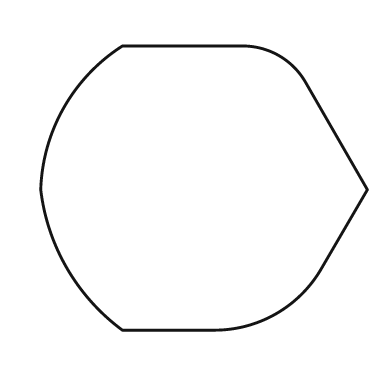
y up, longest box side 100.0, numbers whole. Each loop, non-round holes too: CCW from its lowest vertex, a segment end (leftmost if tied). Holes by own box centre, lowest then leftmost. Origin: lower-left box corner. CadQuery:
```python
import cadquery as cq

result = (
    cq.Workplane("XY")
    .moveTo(25.0, 0.0)
    .lineTo(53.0, 0.0)
    .threePointArc((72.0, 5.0), (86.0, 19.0))
    .lineTo(100.0, 43.0)
    .lineTo(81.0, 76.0)
    .threePointArc((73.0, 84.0), (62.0, 87.0))
    .lineTo(25.0, 87.0)
    .threePointArc((7.0, 68.0), (0.0, 43.0))
    .threePointArc((8.0, 19.0), (25.0, 0.0))
    .close()
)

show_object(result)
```